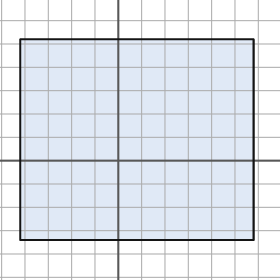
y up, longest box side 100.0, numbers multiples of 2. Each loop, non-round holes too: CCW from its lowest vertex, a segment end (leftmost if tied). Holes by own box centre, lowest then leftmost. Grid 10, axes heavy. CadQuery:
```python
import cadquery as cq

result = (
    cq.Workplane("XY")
    .moveTo(-42.0, -34.0)
    .lineTo(58.0, -34.0)
    .lineTo(58.0, 52.0)
    .lineTo(-42.0, 52.0)
    .close()
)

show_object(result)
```